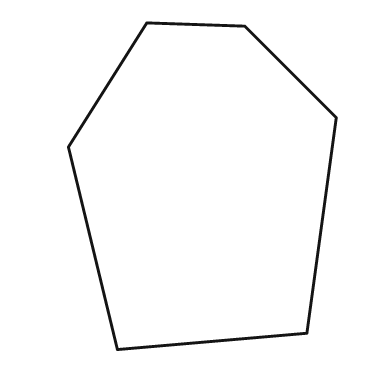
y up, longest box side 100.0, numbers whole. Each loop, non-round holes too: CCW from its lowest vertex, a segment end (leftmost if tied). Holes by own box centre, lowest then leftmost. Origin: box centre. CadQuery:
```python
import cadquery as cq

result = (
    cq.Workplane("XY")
    .moveTo(-26.0, -50.0)
    .lineTo(32.0, -45.0)
    .lineTo(41.0, 21.0)
    .lineTo(13.0, 49.0)
    .lineTo(-17.0, 50.0)
    .lineTo(-41.0, 12.0)
    .close()
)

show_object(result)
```